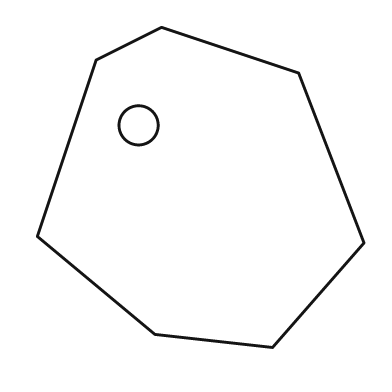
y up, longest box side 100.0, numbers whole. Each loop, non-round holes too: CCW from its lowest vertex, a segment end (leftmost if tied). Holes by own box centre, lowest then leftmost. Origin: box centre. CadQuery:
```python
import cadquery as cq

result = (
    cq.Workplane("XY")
    .moveTo(22.0, -49.0)
    .lineTo(50.0, -17.0)
    .lineTo(30.0, 35.0)
    .lineTo(-12.0, 49.0)
    .lineTo(-32.0, 39.0)
    .lineTo(-50.0, -15.0)
    .lineTo(-14.0, -45.0)
    .close()
    .moveTo(-19.0, 19.0)
    .circle(6.0)
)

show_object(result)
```